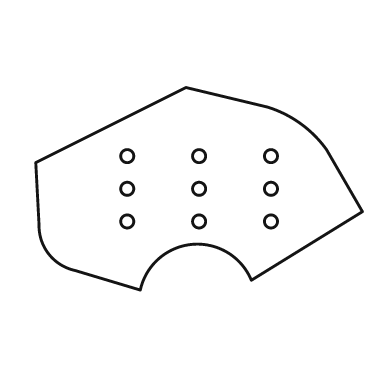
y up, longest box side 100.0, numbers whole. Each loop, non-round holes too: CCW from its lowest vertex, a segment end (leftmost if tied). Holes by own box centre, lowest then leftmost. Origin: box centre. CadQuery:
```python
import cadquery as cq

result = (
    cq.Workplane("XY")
    .moveTo(-18.0, -31.0)
    .threePointArc((-2.0, -17.0), (16.0, -28.0))
    .lineTo(50.0, -7.0)
    .lineTo(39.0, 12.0)
    .threePointArc((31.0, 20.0), (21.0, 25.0))
    .lineTo(-4.0, 31.0)
    .lineTo(-50.0, 8.0)
    .lineTo(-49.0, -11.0)
    .threePointArc((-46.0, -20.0), (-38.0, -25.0))
    .close()
    .moveTo(-22.0, -10.0)
    .circle(2.0)
    .moveTo(0.0, -10.0)
    .circle(2.0)
    .moveTo(22.0, -10.0)
    .circle(2.0)
    .moveTo(-22.0, 0.0)
    .circle(2.0)
    .moveTo(0.0, 0.0)
    .circle(2.0)
    .moveTo(22.0, 0.0)
    .circle(2.0)
    .moveTo(-22.0, 10.0)
    .circle(2.0)
    .moveTo(0.0, 10.0)
    .circle(2.0)
    .moveTo(22.0, 10.0)
    .circle(2.0)
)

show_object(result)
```